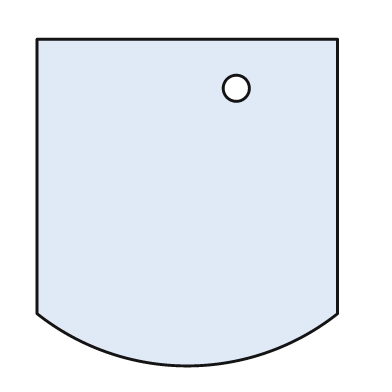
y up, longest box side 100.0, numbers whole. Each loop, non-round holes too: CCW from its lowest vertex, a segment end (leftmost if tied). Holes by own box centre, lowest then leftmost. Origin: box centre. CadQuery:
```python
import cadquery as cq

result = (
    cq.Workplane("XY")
    .moveTo(-46.0, -34.0)
    .threePointArc((0.0, -50.0), (46.0, -34.0))
    .lineTo(46.0, 50.0)
    .lineTo(-46.0, 50.0)
    .close()
    .moveTo(15.0, 35.0)
    .circle(4.0)
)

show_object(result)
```